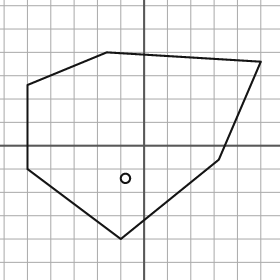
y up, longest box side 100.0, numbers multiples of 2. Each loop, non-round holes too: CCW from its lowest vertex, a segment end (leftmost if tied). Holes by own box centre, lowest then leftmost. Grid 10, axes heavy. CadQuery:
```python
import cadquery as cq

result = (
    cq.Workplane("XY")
    .moveTo(-10.0, -40.0)
    .lineTo(32.0, -6.0)
    .lineTo(50.0, 36.0)
    .lineTo(-16.0, 40.0)
    .lineTo(-50.0, 26.0)
    .lineTo(-50.0, -10.0)
    .close()
    .moveTo(-8.0, -14.0)
    .circle(2.0)
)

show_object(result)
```